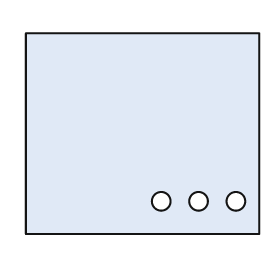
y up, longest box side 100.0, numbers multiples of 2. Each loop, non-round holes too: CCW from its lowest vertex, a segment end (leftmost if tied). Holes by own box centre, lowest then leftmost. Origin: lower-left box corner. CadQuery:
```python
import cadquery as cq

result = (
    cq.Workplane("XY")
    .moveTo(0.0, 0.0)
    .lineTo(100.0, 0.0)
    .lineTo(100.0, 86.0)
    .lineTo(0.0, 86.0)
    .close()
    .moveTo(58.0, 14.0)
    .circle(4.0)
    .moveTo(74.0, 14.0)
    .circle(4.0)
    .moveTo(90.0, 14.0)
    .circle(4.0)
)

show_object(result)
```